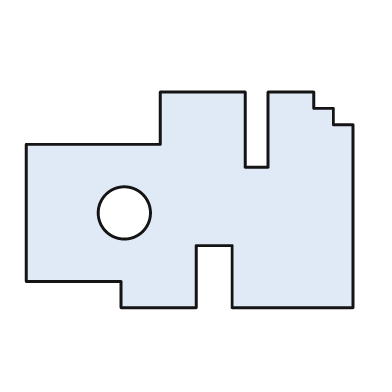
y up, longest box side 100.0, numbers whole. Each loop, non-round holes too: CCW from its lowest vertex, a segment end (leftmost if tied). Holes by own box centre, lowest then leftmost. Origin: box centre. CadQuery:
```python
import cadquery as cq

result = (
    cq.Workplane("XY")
    .moveTo(-21.0, -33.0)
    .lineTo(2.0, -33.0)
    .lineTo(2.0, -14.0)
    .lineTo(13.0, -14.0)
    .lineTo(13.0, -33.0)
    .lineTo(50.0, -33.0)
    .lineTo(50.0, 23.0)
    .lineTo(44.0, 23.0)
    .lineTo(44.0, 28.0)
    .lineTo(38.0, 28.0)
    .lineTo(38.0, 33.0)
    .lineTo(24.0, 33.0)
    .lineTo(24.0, 10.0)
    .lineTo(17.0, 10.0)
    .lineTo(17.0, 33.0)
    .lineTo(-9.0, 33.0)
    .lineTo(-9.0, 17.0)
    .lineTo(-50.0, 17.0)
    .lineTo(-50.0, -25.0)
    .lineTo(-21.0, -25.0)
    .close()
    .moveTo(-20.0, -4.0)
    .circle(8.0)
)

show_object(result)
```